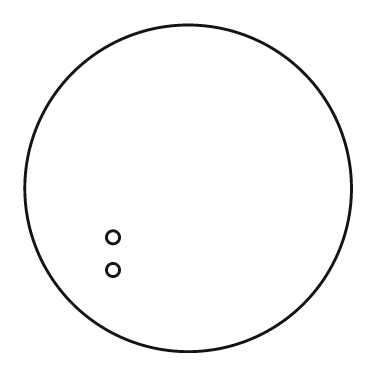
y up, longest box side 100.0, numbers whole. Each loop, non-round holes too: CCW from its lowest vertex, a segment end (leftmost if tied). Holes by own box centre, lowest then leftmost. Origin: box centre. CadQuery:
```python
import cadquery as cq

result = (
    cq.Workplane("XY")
    .moveTo(0.0, 0.0)
    .circle(50.0)
    .moveTo(-23.0, -25.0)
    .circle(2.0)
    .moveTo(-23.0, -15.0)
    .circle(2.0)
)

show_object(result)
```